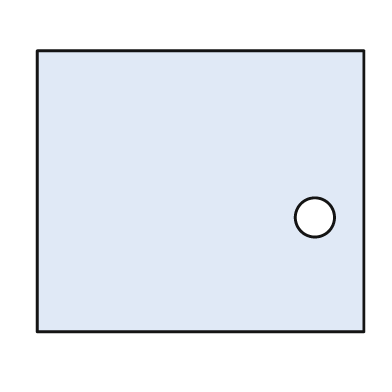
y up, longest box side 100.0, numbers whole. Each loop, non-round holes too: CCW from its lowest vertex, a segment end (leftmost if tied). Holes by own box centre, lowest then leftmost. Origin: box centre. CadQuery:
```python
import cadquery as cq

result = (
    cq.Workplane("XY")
    .moveTo(-50.0, -43.0)
    .lineTo(50.0, -43.0)
    .lineTo(50.0, 43.0)
    .lineTo(-50.0, 43.0)
    .close()
    .moveTo(35.0, -8.0)
    .circle(6.0)
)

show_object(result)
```